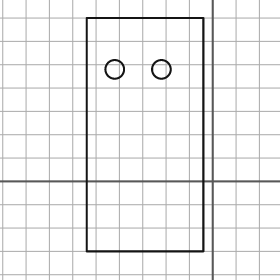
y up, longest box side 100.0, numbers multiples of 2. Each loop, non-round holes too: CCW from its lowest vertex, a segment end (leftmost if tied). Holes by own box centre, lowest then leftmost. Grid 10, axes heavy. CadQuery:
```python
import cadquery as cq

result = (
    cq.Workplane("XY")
    .moveTo(-54.0, -30.0)
    .lineTo(-4.0, -30.0)
    .lineTo(-4.0, 70.0)
    .lineTo(-54.0, 70.0)
    .close()
    .moveTo(-42.0, 48.0)
    .circle(4.0)
    .moveTo(-22.0, 48.0)
    .circle(4.0)
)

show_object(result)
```